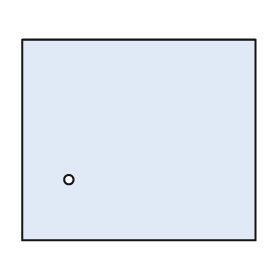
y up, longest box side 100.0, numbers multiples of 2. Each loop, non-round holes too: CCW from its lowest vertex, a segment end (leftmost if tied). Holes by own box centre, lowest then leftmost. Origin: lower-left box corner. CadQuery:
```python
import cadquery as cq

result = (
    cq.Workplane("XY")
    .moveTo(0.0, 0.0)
    .lineTo(100.0, 0.0)
    .lineTo(100.0, 86.0)
    .lineTo(0.0, 86.0)
    .close()
    .moveTo(20.0, 26.0)
    .circle(2.0)
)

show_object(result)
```